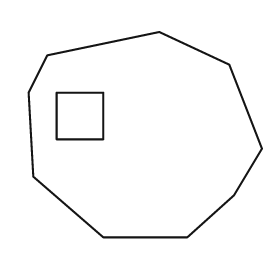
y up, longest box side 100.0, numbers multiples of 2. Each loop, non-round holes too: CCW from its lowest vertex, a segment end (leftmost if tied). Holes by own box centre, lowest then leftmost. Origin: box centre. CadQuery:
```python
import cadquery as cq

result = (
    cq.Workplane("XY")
    .moveTo(-18.0, -44.0)
    .lineTo(18.0, -44.0)
    .lineTo(38.0, -26.0)
    .lineTo(50.0, -6.0)
    .lineTo(36.0, 30.0)
    .lineTo(6.0, 44.0)
    .lineTo(-42.0, 34.0)
    .lineTo(-50.0, 18.0)
    .lineTo(-48.0, -18.0)
    .close()
    .moveTo(-38.0, -2.0)
    .lineTo(-18.0, -2.0)
    .lineTo(-18.0, 18.0)
    .lineTo(-38.0, 18.0)
    .close()
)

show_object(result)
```